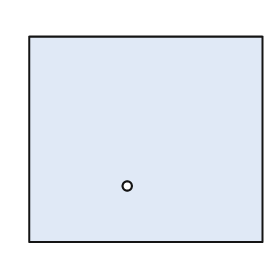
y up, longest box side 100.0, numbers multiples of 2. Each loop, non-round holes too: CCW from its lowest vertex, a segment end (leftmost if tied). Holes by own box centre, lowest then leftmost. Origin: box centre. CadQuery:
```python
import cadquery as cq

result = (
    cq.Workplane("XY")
    .moveTo(-50.0, -44.0)
    .lineTo(50.0, -44.0)
    .lineTo(50.0, 44.0)
    .lineTo(-50.0, 44.0)
    .close()
    .moveTo(-8.0, -20.0)
    .circle(2.0)
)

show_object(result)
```